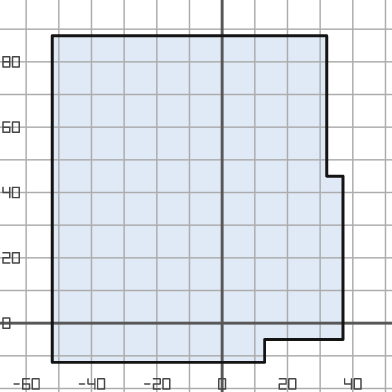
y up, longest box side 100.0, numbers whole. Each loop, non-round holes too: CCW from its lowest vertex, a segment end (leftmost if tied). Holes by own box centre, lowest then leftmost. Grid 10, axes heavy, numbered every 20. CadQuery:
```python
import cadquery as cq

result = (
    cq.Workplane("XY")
    .moveTo(-52.0, -12.0)
    .lineTo(13.0, -12.0)
    .lineTo(13.0, -5.0)
    .lineTo(37.0, -5.0)
    .lineTo(37.0, 45.0)
    .lineTo(32.0, 45.0)
    .lineTo(32.0, 88.0)
    .lineTo(-52.0, 88.0)
    .close()
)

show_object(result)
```